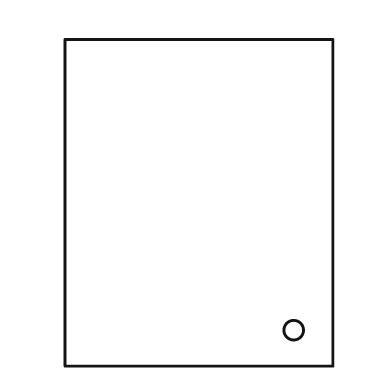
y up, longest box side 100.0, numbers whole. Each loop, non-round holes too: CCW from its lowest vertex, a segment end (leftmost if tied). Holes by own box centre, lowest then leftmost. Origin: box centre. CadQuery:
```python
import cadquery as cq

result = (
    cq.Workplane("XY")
    .moveTo(-41.0, -50.0)
    .lineTo(41.0, -50.0)
    .lineTo(41.0, 50.0)
    .lineTo(-41.0, 50.0)
    .close()
    .moveTo(29.0, -39.0)
    .circle(3.0)
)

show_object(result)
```